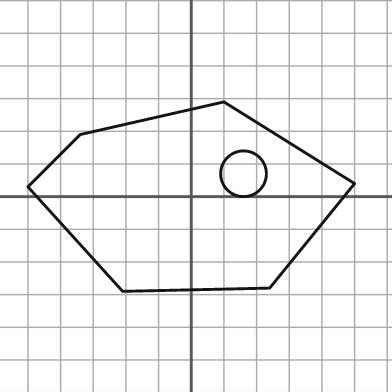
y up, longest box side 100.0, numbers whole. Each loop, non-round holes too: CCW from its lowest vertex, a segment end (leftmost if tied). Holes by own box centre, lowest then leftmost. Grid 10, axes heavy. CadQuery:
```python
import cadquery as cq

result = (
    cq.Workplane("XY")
    .moveTo(-21.0, -29.0)
    .lineTo(24.0, -28.0)
    .lineTo(50.0, 4.0)
    .lineTo(10.0, 29.0)
    .lineTo(-34.0, 19.0)
    .lineTo(-50.0, 3.0)
    .close()
    .moveTo(16.0, 7.0)
    .circle(7.0)
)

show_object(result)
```